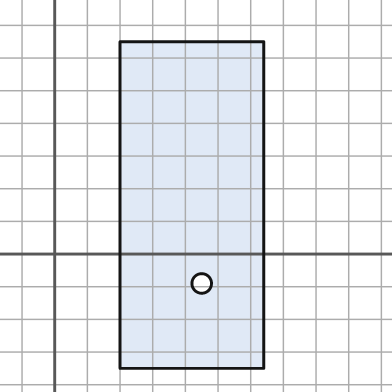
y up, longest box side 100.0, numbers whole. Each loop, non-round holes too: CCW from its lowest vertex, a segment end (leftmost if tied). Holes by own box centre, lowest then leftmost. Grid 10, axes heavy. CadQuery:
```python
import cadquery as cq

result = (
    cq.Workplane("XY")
    .moveTo(20.0, -35.0)
    .lineTo(64.0, -35.0)
    .lineTo(64.0, 65.0)
    .lineTo(20.0, 65.0)
    .close()
    .moveTo(45.0, -9.0)
    .circle(3.0)
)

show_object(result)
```